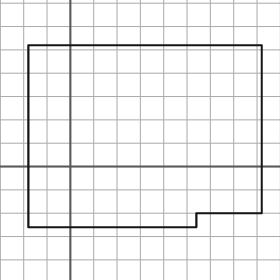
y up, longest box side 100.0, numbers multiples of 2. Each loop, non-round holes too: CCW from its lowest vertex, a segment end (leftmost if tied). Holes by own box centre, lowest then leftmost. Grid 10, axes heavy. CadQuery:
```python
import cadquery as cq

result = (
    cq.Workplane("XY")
    .moveTo(-18.0, -26.0)
    .lineTo(54.0, -26.0)
    .lineTo(54.0, -20.0)
    .lineTo(82.0, -20.0)
    .lineTo(82.0, 52.0)
    .lineTo(-18.0, 52.0)
    .close()
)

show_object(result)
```